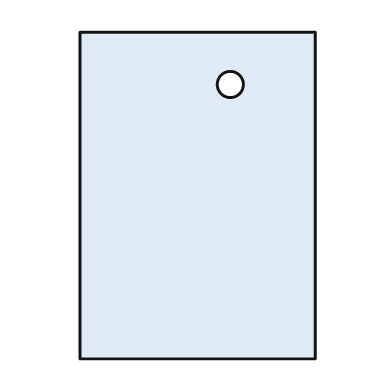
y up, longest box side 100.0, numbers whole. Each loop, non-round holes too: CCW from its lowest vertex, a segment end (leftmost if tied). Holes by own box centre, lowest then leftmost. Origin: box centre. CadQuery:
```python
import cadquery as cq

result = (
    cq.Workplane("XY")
    .moveTo(-36.0, -50.0)
    .lineTo(36.0, -50.0)
    .lineTo(36.0, 50.0)
    .lineTo(-36.0, 50.0)
    .close()
    .moveTo(10.0, 34.0)
    .circle(4.0)
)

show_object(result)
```